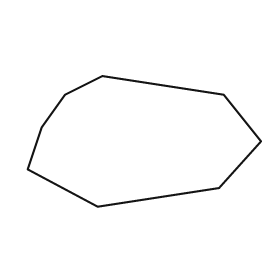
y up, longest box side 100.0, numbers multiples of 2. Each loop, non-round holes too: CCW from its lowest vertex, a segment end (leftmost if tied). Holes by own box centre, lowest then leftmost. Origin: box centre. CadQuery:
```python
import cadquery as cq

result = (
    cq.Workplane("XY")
    .moveTo(-20.0, -28.0)
    .lineTo(32.0, -20.0)
    .lineTo(50.0, 0.0)
    .lineTo(34.0, 20.0)
    .lineTo(-18.0, 28.0)
    .lineTo(-34.0, 20.0)
    .lineTo(-44.0, 6.0)
    .lineTo(-50.0, -12.0)
    .close()
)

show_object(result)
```